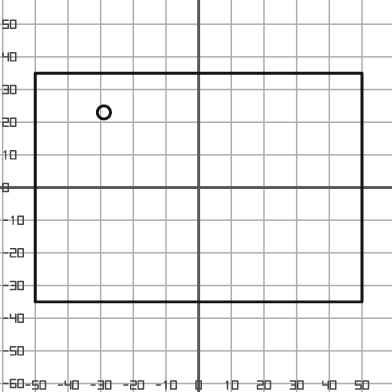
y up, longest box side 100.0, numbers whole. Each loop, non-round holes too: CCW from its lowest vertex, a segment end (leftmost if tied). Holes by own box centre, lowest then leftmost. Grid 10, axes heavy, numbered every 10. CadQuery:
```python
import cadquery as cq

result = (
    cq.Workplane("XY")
    .moveTo(-50.0, -35.0)
    .lineTo(50.0, -35.0)
    .lineTo(50.0, 35.0)
    .lineTo(-50.0, 35.0)
    .close()
    .moveTo(-29.0, 23.0)
    .circle(2.0)
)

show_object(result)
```